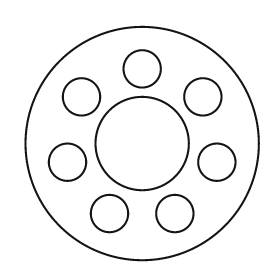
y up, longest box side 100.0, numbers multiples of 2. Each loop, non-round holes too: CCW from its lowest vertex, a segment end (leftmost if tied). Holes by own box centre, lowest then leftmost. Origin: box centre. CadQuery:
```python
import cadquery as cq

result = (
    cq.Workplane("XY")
    .moveTo(0.0, 0.0)
    .circle(50.0)
    .moveTo(-14.0, -30.0)
    .circle(8.0)
    .moveTo(14.0, -30.0)
    .circle(8.0)
    .moveTo(-32.0, -8.0)
    .circle(8.0)
    .moveTo(32.0, -8.0)
    .circle(8.0)
    .moveTo(0.0, 0.0)
    .circle(20.0)
    .moveTo(-26.0, 20.0)
    .circle(8.0)
    .moveTo(26.0, 20.0)
    .circle(8.0)
    .moveTo(0.0, 32.0)
    .circle(8.0)
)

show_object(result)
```